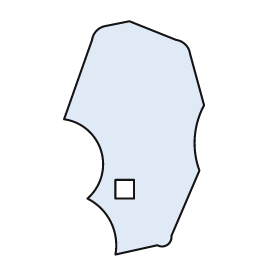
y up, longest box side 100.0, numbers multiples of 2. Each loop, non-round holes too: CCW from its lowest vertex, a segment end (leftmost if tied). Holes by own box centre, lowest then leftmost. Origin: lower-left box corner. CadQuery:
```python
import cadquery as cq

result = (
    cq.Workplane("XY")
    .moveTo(22.0, 0.0)
    .lineTo(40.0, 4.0)
    .threePointArc((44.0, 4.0), (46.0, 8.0))
    .lineTo(58.0, 36.0)
    .threePointArc((56.0, 50.0), (60.0, 64.0))
    .lineTo(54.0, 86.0)
    .threePointArc((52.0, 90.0), (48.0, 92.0))
    .lineTo(28.0, 100.0)
    .lineTo(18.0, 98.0)
    .threePointArc((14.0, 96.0), (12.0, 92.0))
    .lineTo(0.0, 58.0)
    .threePointArc((16.0, 44.0), (10.0, 24.0))
    .threePointArc((20.0, 14.0), (22.0, 0.0))
    .close()
    .moveTo(22.0, 24.0)
    .lineTo(30.0, 24.0)
    .lineTo(30.0, 32.0)
    .lineTo(22.0, 32.0)
    .close()
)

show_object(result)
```